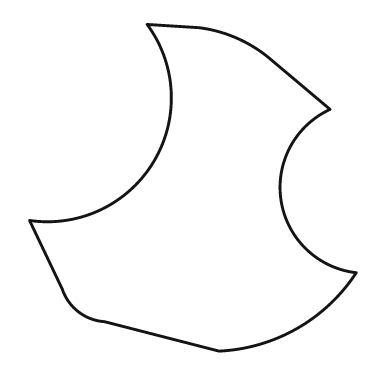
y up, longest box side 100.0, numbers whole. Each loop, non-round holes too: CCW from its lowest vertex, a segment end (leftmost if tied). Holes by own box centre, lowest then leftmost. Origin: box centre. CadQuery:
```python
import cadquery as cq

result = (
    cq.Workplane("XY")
    .moveTo(8.0, -50.0)
    .threePointArc((32.0, -43.0), (50.0, -26.0))
    .threePointArc((27.0, -4.0), (42.0, 24.0))
    .lineTo(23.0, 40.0)
    .threePointArc((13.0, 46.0), (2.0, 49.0))
    .lineTo(-14.0, 50.0)
    .threePointArc((-12.0, 8.0), (-50.0, -10.0))
    .lineTo(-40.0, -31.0)
    .threePointArc((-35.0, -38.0), (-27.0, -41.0))
    .close()
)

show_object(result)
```